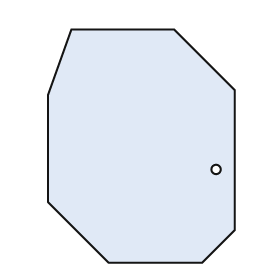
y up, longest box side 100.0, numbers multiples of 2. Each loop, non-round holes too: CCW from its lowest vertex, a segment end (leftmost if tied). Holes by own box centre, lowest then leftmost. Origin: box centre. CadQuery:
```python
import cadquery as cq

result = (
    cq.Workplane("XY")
    .moveTo(-14.0, -50.0)
    .lineTo(26.0, -50.0)
    .lineTo(40.0, -36.0)
    .lineTo(40.0, 24.0)
    .lineTo(14.0, 50.0)
    .lineTo(-30.0, 50.0)
    .lineTo(-40.0, 22.0)
    .lineTo(-40.0, -24.0)
    .close()
    .moveTo(32.0, -10.0)
    .circle(2.0)
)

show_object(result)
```